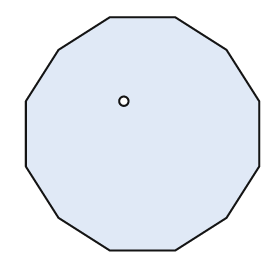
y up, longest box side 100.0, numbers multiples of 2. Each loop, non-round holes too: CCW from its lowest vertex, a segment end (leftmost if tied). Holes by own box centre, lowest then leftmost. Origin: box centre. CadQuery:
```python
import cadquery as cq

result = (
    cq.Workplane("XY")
    .moveTo(-14.0, -50.0)
    .lineTo(14.0, -50.0)
    .lineTo(36.0, -36.0)
    .lineTo(50.0, -14.0)
    .lineTo(50.0, 14.0)
    .lineTo(36.0, 36.0)
    .lineTo(14.0, 50.0)
    .lineTo(-14.0, 50.0)
    .lineTo(-36.0, 36.0)
    .lineTo(-50.0, 14.0)
    .lineTo(-50.0, -14.0)
    .lineTo(-36.0, -36.0)
    .close()
    .moveTo(-8.0, 14.0)
    .circle(2.0)
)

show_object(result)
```